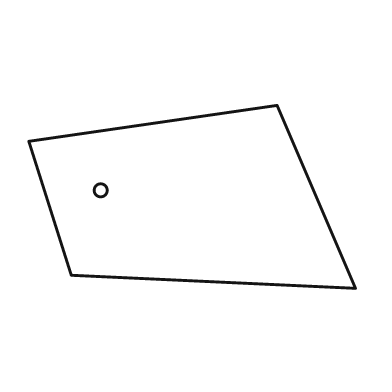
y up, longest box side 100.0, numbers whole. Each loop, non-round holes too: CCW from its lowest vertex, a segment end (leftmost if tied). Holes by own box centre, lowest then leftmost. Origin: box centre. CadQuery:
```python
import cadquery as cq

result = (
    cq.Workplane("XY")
    .moveTo(50.0, -28.0)
    .lineTo(26.0, 28.0)
    .lineTo(-50.0, 17.0)
    .lineTo(-37.0, -24.0)
    .close()
    .moveTo(-28.0, 2.0)
    .circle(2.0)
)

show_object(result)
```